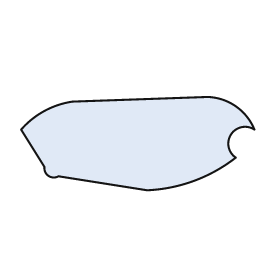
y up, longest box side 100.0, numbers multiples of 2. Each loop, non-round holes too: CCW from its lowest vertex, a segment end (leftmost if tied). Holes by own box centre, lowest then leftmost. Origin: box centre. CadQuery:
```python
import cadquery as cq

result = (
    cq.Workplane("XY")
    .moveTo(4.0, -20.0)
    .threePointArc((24.0, -16.0), (42.0, -6.0))
    .threePointArc((40.0, 4.0), (50.0, 6.0))
    .threePointArc((42.0, 16.0), (30.0, 20.0))
    .lineTo(-28.0, 18.0)
    .threePointArc((-40.0, 14.0), (-50.0, 6.0))
    .lineTo(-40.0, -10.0)
    .threePointArc((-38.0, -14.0), (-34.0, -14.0))
    .close()
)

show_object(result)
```